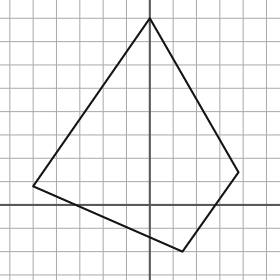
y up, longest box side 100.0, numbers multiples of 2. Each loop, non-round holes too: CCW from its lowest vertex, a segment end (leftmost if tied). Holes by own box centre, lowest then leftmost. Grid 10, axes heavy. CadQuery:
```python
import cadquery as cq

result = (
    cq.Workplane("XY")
    .moveTo(14.0, -20.0)
    .lineTo(38.0, 14.0)
    .lineTo(0.0, 80.0)
    .lineTo(-50.0, 8.0)
    .close()
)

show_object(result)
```